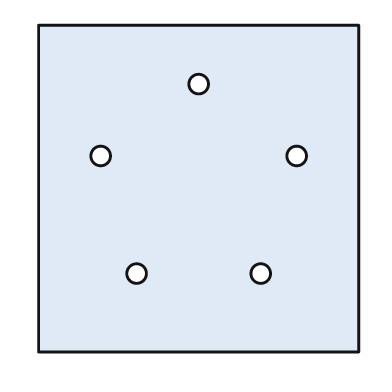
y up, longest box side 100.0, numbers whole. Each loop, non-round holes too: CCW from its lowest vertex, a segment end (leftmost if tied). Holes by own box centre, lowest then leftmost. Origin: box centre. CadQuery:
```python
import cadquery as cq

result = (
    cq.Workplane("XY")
    .moveTo(-49.0, -50.0)
    .lineTo(49.0, -50.0)
    .lineTo(49.0, 50.0)
    .lineTo(-49.0, 50.0)
    .close()
    .moveTo(-19.0, -26.0)
    .circle(3.0)
    .moveTo(19.0, -26.0)
    .circle(3.0)
    .moveTo(-30.0, 10.0)
    .circle(3.0)
    .moveTo(30.0, 10.0)
    .circle(3.0)
    .moveTo(0.0, 32.0)
    .circle(3.0)
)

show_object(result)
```